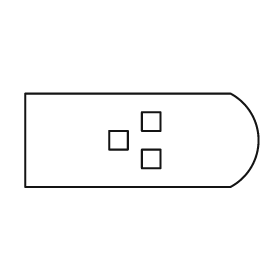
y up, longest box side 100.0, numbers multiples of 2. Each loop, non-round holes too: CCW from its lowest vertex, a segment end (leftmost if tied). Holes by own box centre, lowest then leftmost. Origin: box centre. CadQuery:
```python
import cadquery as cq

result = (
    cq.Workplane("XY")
    .moveTo(-50.0, -20.0)
    .lineTo(38.0, -20.0)
    .threePointArc((50.0, 0.0), (38.0, 20.0))
    .lineTo(-50.0, 20.0)
    .close()
    .moveTo(0.0, -12.0)
    .lineTo(8.0, -12.0)
    .lineTo(8.0, -4.0)
    .lineTo(0.0, -4.0)
    .close()
    .moveTo(-14.0, -4.0)
    .lineTo(-6.0, -4.0)
    .lineTo(-6.0, 4.0)
    .lineTo(-14.0, 4.0)
    .close()
    .moveTo(0.0, 4.0)
    .lineTo(8.0, 4.0)
    .lineTo(8.0, 12.0)
    .lineTo(0.0, 12.0)
    .close()
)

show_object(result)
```